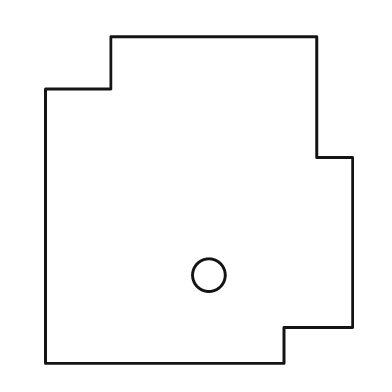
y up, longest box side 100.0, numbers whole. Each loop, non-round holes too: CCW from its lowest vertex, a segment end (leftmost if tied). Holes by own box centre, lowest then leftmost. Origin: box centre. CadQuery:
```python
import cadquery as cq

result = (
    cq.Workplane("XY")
    .moveTo(-47.0, -50.0)
    .lineTo(26.0, -50.0)
    .lineTo(26.0, -39.0)
    .lineTo(47.0, -39.0)
    .lineTo(47.0, 13.0)
    .lineTo(36.0, 13.0)
    .lineTo(36.0, 50.0)
    .lineTo(-27.0, 50.0)
    .lineTo(-27.0, 34.0)
    .lineTo(-47.0, 34.0)
    .close()
    .moveTo(3.0, -23.0)
    .circle(5.0)
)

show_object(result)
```